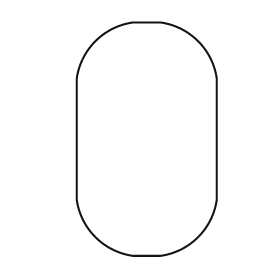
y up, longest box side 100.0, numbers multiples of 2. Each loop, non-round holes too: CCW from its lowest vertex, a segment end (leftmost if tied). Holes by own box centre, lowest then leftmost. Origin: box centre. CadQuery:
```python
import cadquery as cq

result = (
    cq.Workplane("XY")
    .moveTo(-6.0, -50.0)
    .lineTo(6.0, -50.0)
    .threePointArc((22.0, -42.0), (30.0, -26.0))
    .lineTo(30.0, 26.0)
    .threePointArc((22.0, 42.0), (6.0, 50.0))
    .lineTo(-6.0, 50.0)
    .threePointArc((-22.0, 42.0), (-30.0, 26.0))
    .lineTo(-30.0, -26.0)
    .threePointArc((-22.0, -42.0), (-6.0, -50.0))
    .close()
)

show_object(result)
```